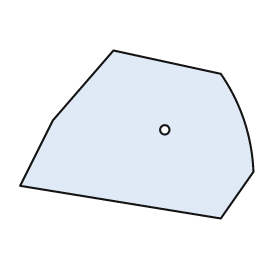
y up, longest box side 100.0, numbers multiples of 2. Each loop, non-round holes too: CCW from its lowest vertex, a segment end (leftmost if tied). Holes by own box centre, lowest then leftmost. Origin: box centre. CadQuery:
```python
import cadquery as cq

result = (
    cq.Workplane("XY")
    .moveTo(36.0, -36.0)
    .lineTo(50.0, -16.0)
    .threePointArc((46.0, 6.0), (36.0, 26.0))
    .lineTo(-10.0, 36.0)
    .lineTo(-36.0, 6.0)
    .lineTo(-50.0, -22.0)
    .close()
    .moveTo(12.0, 2.0)
    .circle(2.0)
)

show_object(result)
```